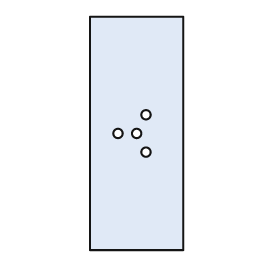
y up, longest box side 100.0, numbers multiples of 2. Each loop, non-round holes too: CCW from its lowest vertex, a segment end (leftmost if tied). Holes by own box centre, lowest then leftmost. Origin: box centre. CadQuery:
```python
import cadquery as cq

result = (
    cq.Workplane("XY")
    .moveTo(-20.0, -50.0)
    .lineTo(20.0, -50.0)
    .lineTo(20.0, 50.0)
    .lineTo(-20.0, 50.0)
    .close()
    .moveTo(4.0, -8.0)
    .circle(2.0)
    .moveTo(-8.0, 0.0)
    .circle(2.0)
    .moveTo(0.0, 0.0)
    .circle(2.0)
    .moveTo(4.0, 8.0)
    .circle(2.0)
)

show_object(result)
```